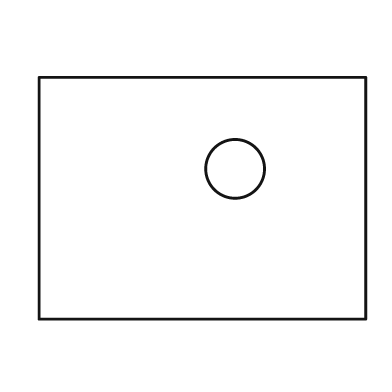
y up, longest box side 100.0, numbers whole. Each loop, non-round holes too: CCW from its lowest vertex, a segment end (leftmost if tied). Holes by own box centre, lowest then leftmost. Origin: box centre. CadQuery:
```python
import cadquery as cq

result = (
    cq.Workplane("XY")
    .moveTo(-50.0, -37.0)
    .lineTo(50.0, -37.0)
    .lineTo(50.0, 37.0)
    .lineTo(-50.0, 37.0)
    .close()
    .moveTo(10.0, 9.0)
    .circle(9.0)
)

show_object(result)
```